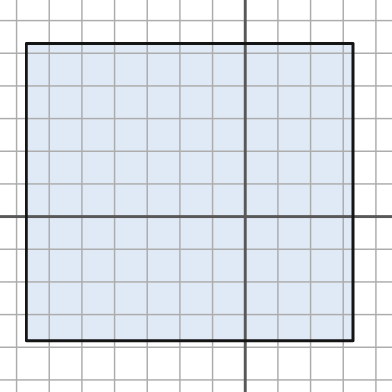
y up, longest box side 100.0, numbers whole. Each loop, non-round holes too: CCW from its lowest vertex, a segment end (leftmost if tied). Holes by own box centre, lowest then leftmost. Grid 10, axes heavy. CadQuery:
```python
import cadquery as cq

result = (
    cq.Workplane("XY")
    .moveTo(-67.0, -38.0)
    .lineTo(33.0, -38.0)
    .lineTo(33.0, 53.0)
    .lineTo(-67.0, 53.0)
    .close()
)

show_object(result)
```